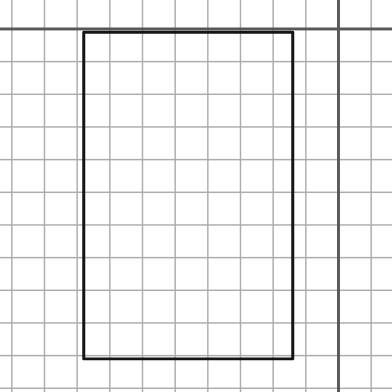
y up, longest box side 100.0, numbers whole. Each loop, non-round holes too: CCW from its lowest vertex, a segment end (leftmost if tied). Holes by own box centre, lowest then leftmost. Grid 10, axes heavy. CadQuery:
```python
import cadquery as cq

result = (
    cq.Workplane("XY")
    .moveTo(-78.0, -101.0)
    .lineTo(-14.0, -101.0)
    .lineTo(-14.0, -1.0)
    .lineTo(-78.0, -1.0)
    .close()
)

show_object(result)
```